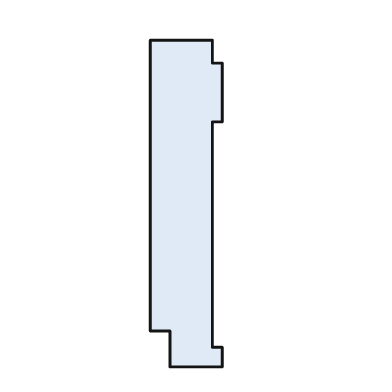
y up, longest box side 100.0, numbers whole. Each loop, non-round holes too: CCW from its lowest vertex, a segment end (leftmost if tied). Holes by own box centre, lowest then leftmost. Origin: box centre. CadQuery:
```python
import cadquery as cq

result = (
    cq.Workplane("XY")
    .moveTo(-5.0, -50.0)
    .lineTo(11.0, -50.0)
    .lineTo(11.0, -44.0)
    .lineTo(8.0, -44.0)
    .lineTo(8.0, 25.0)
    .lineTo(11.0, 25.0)
    .lineTo(11.0, 43.0)
    .lineTo(8.0, 43.0)
    .lineTo(8.0, 50.0)
    .lineTo(-11.0, 50.0)
    .lineTo(-11.0, -39.0)
    .lineTo(-5.0, -39.0)
    .close()
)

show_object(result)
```